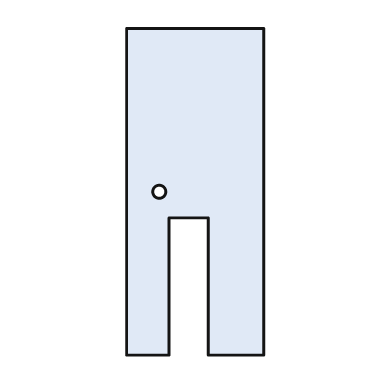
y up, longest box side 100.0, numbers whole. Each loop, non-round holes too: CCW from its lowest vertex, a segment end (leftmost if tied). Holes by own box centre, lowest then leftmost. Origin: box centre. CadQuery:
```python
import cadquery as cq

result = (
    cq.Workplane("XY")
    .moveTo(-21.0, -50.0)
    .lineTo(-8.0, -50.0)
    .lineTo(-8.0, -8.0)
    .lineTo(4.0, -8.0)
    .lineTo(4.0, -50.0)
    .lineTo(21.0, -50.0)
    .lineTo(21.0, 50.0)
    .lineTo(-21.0, 50.0)
    .close()
    .moveTo(-11.0, 0.0)
    .circle(2.0)
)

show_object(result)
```